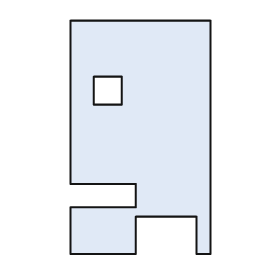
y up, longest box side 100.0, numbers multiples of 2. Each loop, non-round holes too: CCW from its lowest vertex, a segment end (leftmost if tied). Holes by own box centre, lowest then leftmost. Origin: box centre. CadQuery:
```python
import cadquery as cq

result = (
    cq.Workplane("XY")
    .moveTo(-30.0, -50.0)
    .lineTo(-2.0, -50.0)
    .lineTo(-2.0, -34.0)
    .lineTo(24.0, -34.0)
    .lineTo(24.0, -50.0)
    .lineTo(30.0, -50.0)
    .lineTo(30.0, 50.0)
    .lineTo(-30.0, 50.0)
    .lineTo(-30.0, -20.0)
    .lineTo(-2.0, -20.0)
    .lineTo(-2.0, -30.0)
    .lineTo(-30.0, -30.0)
    .close()
    .moveTo(-20.0, 14.0)
    .lineTo(-8.0, 14.0)
    .lineTo(-8.0, 26.0)
    .lineTo(-20.0, 26.0)
    .close()
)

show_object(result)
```